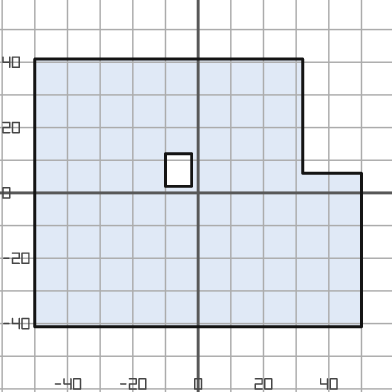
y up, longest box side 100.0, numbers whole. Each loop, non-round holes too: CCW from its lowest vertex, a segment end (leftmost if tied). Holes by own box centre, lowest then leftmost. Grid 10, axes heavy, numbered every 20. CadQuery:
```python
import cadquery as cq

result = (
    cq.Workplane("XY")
    .moveTo(-50.0, -41.0)
    .lineTo(50.0, -41.0)
    .lineTo(50.0, 6.0)
    .lineTo(32.0, 6.0)
    .lineTo(32.0, 41.0)
    .lineTo(-50.0, 41.0)
    .close()
    .moveTo(-10.0, 2.0)
    .lineTo(-2.0, 2.0)
    .lineTo(-2.0, 12.0)
    .lineTo(-10.0, 12.0)
    .close()
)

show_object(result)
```